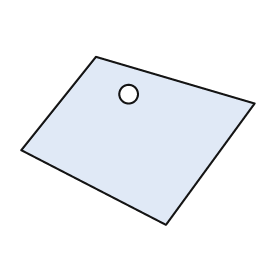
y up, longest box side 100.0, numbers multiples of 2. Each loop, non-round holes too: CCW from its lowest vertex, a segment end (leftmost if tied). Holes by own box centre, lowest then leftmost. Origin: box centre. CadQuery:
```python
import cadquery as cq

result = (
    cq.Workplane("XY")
    .moveTo(12.0, -36.0)
    .lineTo(50.0, 16.0)
    .lineTo(-18.0, 36.0)
    .lineTo(-50.0, -4.0)
    .close()
    .moveTo(-4.0, 20.0)
    .circle(4.0)
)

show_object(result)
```